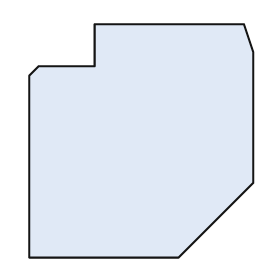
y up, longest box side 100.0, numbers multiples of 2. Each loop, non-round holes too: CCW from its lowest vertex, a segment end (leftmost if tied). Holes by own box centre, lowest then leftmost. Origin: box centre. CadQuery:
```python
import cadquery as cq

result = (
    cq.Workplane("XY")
    .moveTo(-48.0, -50.0)
    .lineTo(16.0, -50.0)
    .lineTo(48.0, -18.0)
    .lineTo(48.0, 38.0)
    .lineTo(44.0, 50.0)
    .lineTo(-20.0, 50.0)
    .lineTo(-20.0, 32.0)
    .lineTo(-44.0, 32.0)
    .lineTo(-48.0, 28.0)
    .close()
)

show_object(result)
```